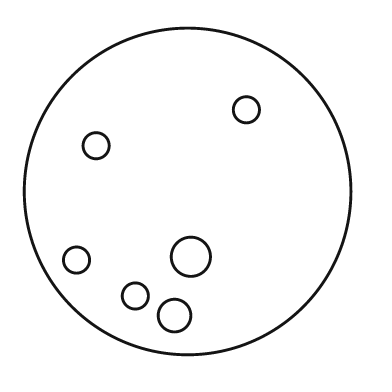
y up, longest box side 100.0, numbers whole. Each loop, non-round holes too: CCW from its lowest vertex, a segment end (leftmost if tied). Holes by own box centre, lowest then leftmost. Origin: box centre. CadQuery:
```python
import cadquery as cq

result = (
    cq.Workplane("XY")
    .moveTo(0.0, 0.0)
    .circle(50.0)
    .moveTo(-4.0, -38.0)
    .circle(5.0)
    .moveTo(-16.0, -32.0)
    .circle(4.0)
    .moveTo(-34.0, -21.0)
    .circle(4.0)
    .moveTo(1.0, -20.0)
    .circle(6.0)
    .moveTo(-28.0, 14.0)
    .circle(4.0)
    .moveTo(18.0, 25.0)
    .circle(4.0)
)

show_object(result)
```